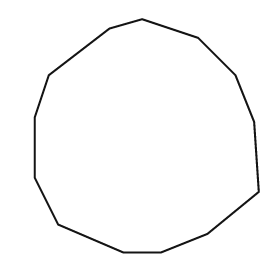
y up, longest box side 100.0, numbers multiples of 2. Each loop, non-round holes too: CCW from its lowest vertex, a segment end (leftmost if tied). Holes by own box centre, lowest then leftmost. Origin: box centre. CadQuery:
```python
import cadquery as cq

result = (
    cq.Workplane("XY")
    .moveTo(-10.0, -50.0)
    .lineTo(6.0, -50.0)
    .lineTo(26.0, -42.0)
    .lineTo(48.0, -24.0)
    .lineTo(46.0, 6.0)
    .lineTo(38.0, 26.0)
    .lineTo(22.0, 42.0)
    .lineTo(-2.0, 50.0)
    .lineTo(-16.0, 46.0)
    .lineTo(-42.0, 26.0)
    .lineTo(-48.0, 8.0)
    .lineTo(-48.0, -18.0)
    .lineTo(-38.0, -38.0)
    .close()
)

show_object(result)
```